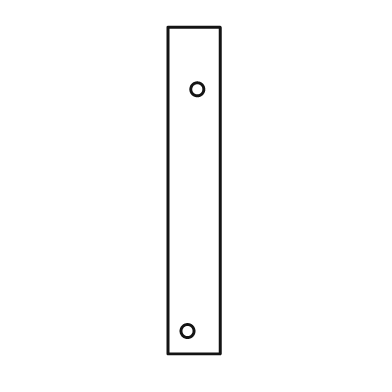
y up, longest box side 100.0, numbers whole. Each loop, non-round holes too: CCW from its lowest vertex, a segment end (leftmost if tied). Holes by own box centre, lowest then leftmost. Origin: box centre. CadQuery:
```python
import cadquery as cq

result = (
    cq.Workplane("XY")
    .moveTo(-8.0, -50.0)
    .lineTo(8.0, -50.0)
    .lineTo(8.0, 50.0)
    .lineTo(-8.0, 50.0)
    .close()
    .moveTo(-2.0, -43.0)
    .circle(2.0)
    .moveTo(1.0, 31.0)
    .circle(2.0)
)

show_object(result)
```